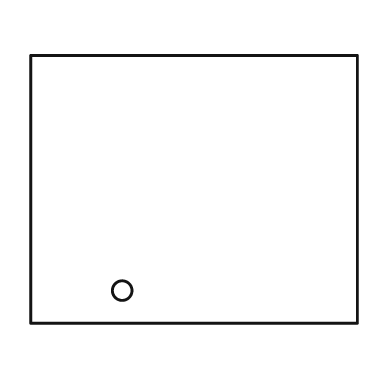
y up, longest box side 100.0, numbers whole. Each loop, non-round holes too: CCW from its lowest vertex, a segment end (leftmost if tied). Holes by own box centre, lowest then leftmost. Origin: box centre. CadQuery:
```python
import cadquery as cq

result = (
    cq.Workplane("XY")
    .moveTo(-50.0, -41.0)
    .lineTo(50.0, -41.0)
    .lineTo(50.0, 41.0)
    .lineTo(-50.0, 41.0)
    .close()
    .moveTo(-22.0, -31.0)
    .circle(3.0)
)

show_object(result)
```